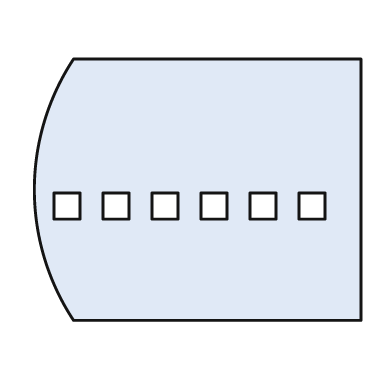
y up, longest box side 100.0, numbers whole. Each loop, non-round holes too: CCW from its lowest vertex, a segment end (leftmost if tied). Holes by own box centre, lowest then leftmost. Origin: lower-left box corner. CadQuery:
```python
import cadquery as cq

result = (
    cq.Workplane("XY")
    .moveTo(12.0, 0.0)
    .lineTo(100.0, 0.0)
    .lineTo(100.0, 80.0)
    .lineTo(12.0, 80.0)
    .threePointArc((0.0, 40.0), (12.0, 0.0))
    .close()
    .moveTo(6.0, 31.0)
    .lineTo(14.0, 31.0)
    .lineTo(14.0, 39.0)
    .lineTo(6.0, 39.0)
    .close()
    .moveTo(21.0, 31.0)
    .lineTo(29.0, 31.0)
    .lineTo(29.0, 39.0)
    .lineTo(21.0, 39.0)
    .close()
    .moveTo(36.0, 31.0)
    .lineTo(44.0, 31.0)
    .lineTo(44.0, 39.0)
    .lineTo(36.0, 39.0)
    .close()
    .moveTo(51.0, 31.0)
    .lineTo(59.0, 31.0)
    .lineTo(59.0, 39.0)
    .lineTo(51.0, 39.0)
    .close()
    .moveTo(66.0, 31.0)
    .lineTo(74.0, 31.0)
    .lineTo(74.0, 39.0)
    .lineTo(66.0, 39.0)
    .close()
    .moveTo(81.0, 31.0)
    .lineTo(89.0, 31.0)
    .lineTo(89.0, 39.0)
    .lineTo(81.0, 39.0)
    .close()
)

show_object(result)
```